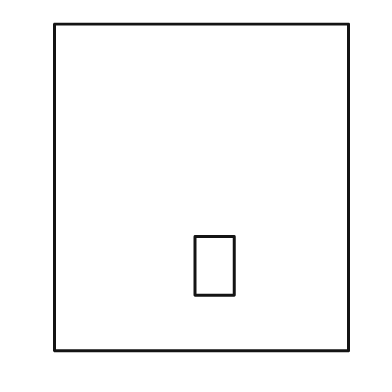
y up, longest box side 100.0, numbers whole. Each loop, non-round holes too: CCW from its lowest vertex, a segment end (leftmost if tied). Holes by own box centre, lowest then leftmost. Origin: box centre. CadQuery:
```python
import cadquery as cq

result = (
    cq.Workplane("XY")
    .moveTo(-45.0, -50.0)
    .lineTo(45.0, -50.0)
    .lineTo(45.0, 50.0)
    .lineTo(-45.0, 50.0)
    .close()
    .moveTo(-2.0, -33.0)
    .lineTo(10.0, -33.0)
    .lineTo(10.0, -15.0)
    .lineTo(-2.0, -15.0)
    .close()
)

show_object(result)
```